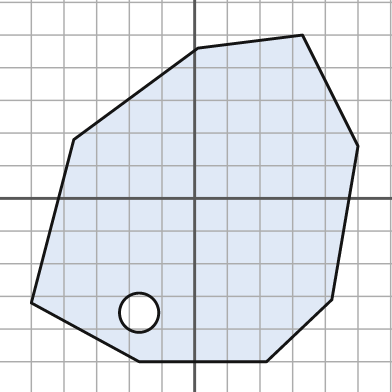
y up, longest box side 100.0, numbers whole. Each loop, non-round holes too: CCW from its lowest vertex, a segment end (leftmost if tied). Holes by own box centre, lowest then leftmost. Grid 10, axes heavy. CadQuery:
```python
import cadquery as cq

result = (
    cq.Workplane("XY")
    .moveTo(-17.0, -50.0)
    .lineTo(22.0, -50.0)
    .lineTo(42.0, -31.0)
    .lineTo(50.0, 16.0)
    .lineTo(33.0, 50.0)
    .lineTo(1.0, 46.0)
    .lineTo(-37.0, 18.0)
    .lineTo(-50.0, -32.0)
    .close()
    .moveTo(-17.0, -35.0)
    .circle(6.0)
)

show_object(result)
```